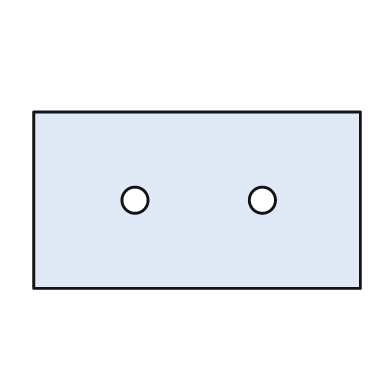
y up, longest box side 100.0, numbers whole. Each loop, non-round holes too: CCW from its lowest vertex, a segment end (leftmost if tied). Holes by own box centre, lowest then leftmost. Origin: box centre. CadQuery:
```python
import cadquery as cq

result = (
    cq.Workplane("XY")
    .moveTo(-50.0, -27.0)
    .lineTo(50.0, -27.0)
    .lineTo(50.0, 27.0)
    .lineTo(-50.0, 27.0)
    .close()
    .moveTo(-19.0, 0.0)
    .circle(4.0)
    .moveTo(20.0, 0.0)
    .circle(4.0)
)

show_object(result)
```